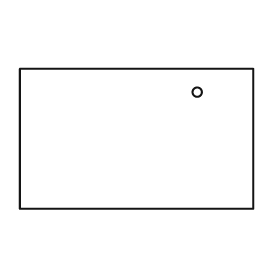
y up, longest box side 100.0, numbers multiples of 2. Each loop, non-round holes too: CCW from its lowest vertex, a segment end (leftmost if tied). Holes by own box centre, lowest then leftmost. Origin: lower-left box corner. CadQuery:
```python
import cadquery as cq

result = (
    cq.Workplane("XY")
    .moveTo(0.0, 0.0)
    .lineTo(100.0, 0.0)
    .lineTo(100.0, 60.0)
    .lineTo(0.0, 60.0)
    .close()
    .moveTo(76.0, 50.0)
    .circle(2.0)
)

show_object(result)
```